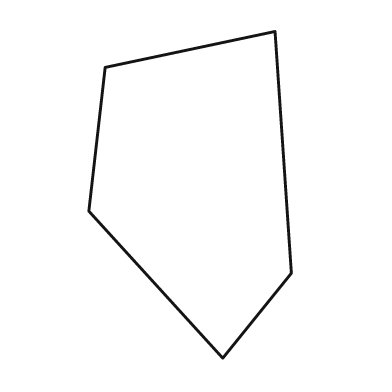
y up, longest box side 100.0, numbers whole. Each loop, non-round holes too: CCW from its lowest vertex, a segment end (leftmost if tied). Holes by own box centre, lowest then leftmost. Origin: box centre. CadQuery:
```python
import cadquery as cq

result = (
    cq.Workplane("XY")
    .moveTo(10.0, -50.0)
    .lineTo(31.0, -24.0)
    .lineTo(26.0, 50.0)
    .lineTo(-26.0, 39.0)
    .lineTo(-31.0, -5.0)
    .close()
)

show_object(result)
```